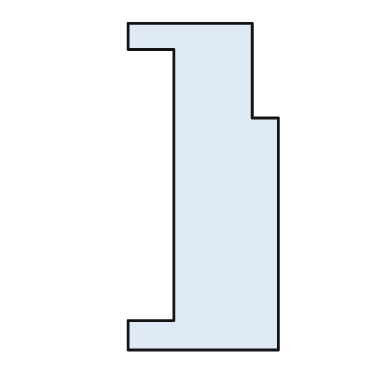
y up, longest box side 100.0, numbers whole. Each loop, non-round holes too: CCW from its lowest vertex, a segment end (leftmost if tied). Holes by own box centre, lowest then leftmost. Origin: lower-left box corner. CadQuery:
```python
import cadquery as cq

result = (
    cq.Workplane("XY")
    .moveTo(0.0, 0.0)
    .lineTo(46.0, 0.0)
    .lineTo(46.0, 71.0)
    .lineTo(38.0, 71.0)
    .lineTo(38.0, 100.0)
    .lineTo(0.0, 100.0)
    .lineTo(0.0, 92.0)
    .lineTo(14.0, 92.0)
    .lineTo(14.0, 9.0)
    .lineTo(0.0, 9.0)
    .close()
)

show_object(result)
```